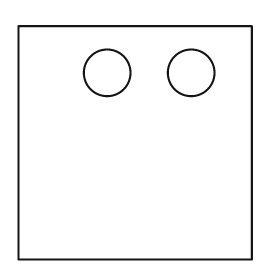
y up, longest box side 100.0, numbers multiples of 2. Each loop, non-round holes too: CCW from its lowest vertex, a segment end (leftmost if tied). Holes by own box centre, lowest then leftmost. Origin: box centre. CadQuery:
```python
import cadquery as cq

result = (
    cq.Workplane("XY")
    .moveTo(-50.0, -50.0)
    .lineTo(50.0, -50.0)
    .lineTo(50.0, 50.0)
    .lineTo(-50.0, 50.0)
    .close()
    .moveTo(-12.0, 30.0)
    .circle(10.0)
    .moveTo(24.0, 30.0)
    .circle(10.0)
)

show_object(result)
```